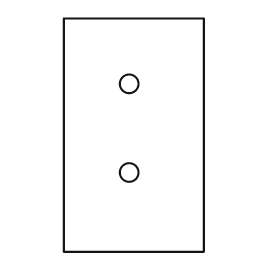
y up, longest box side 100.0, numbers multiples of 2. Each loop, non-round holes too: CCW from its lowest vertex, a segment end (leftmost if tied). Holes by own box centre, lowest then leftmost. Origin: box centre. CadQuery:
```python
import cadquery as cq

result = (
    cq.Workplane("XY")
    .moveTo(-30.0, -50.0)
    .lineTo(30.0, -50.0)
    .lineTo(30.0, 50.0)
    .lineTo(-30.0, 50.0)
    .close()
    .moveTo(-2.0, -16.0)
    .circle(4.0)
    .moveTo(-2.0, 22.0)
    .circle(4.0)
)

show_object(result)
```